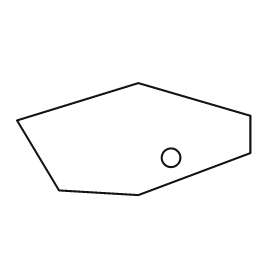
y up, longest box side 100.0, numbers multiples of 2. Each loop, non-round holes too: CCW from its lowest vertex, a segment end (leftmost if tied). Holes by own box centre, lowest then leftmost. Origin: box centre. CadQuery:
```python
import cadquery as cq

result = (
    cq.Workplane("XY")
    .moveTo(2.0, -24.0)
    .lineTo(50.0, -6.0)
    .lineTo(50.0, 10.0)
    .lineTo(2.0, 24.0)
    .lineTo(-50.0, 8.0)
    .lineTo(-32.0, -22.0)
    .close()
    .moveTo(16.0, -8.0)
    .circle(4.0)
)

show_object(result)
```